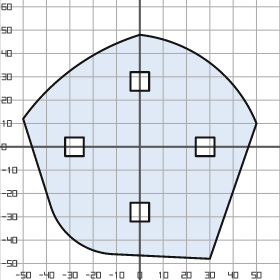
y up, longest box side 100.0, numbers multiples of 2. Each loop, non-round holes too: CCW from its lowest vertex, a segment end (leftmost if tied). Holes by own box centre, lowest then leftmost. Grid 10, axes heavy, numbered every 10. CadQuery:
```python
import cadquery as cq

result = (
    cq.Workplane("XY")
    .moveTo(30.0, -48.0)
    .lineTo(50.0, 10.0)
    .threePointArc((30.0, 36.0), (0.0, 48.0))
    .threePointArc((-28.0, 34.0), (-50.0, 12.0))
    .lineTo(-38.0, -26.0)
    .threePointArc((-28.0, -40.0), (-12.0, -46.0))
    .close()
    .moveTo(-4.0, -32.0)
    .lineTo(4.0, -32.0)
    .lineTo(4.0, -24.0)
    .lineTo(-4.0, -24.0)
    .close()
    .moveTo(-32.0, -4.0)
    .lineTo(-24.0, -4.0)
    .lineTo(-24.0, 4.0)
    .lineTo(-32.0, 4.0)
    .close()
    .moveTo(24.0, -4.0)
    .lineTo(32.0, -4.0)
    .lineTo(32.0, 4.0)
    .lineTo(24.0, 4.0)
    .close()
    .moveTo(-4.0, 24.0)
    .lineTo(4.0, 24.0)
    .lineTo(4.0, 32.0)
    .lineTo(-4.0, 32.0)
    .close()
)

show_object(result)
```